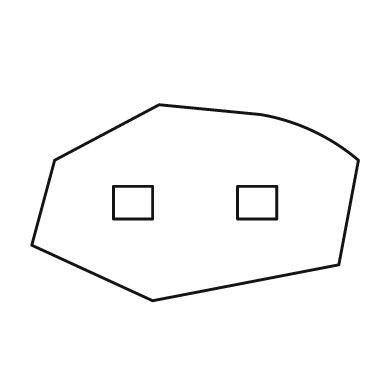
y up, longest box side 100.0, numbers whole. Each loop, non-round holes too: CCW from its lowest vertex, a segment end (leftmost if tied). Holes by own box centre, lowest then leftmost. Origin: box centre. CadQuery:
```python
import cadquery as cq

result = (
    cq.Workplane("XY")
    .moveTo(-13.0, -30.0)
    .lineTo(44.0, -19.0)
    .lineTo(50.0, 13.0)
    .threePointArc((36.0, 22.0), (20.0, 27.0))
    .lineTo(-11.0, 30.0)
    .lineTo(-43.0, 13.0)
    .lineTo(-50.0, -13.0)
    .close()
    .moveTo(-25.0, -5.0)
    .lineTo(-13.0, -5.0)
    .lineTo(-13.0, 5.0)
    .lineTo(-25.0, 5.0)
    .close()
    .moveTo(13.0, -5.0)
    .lineTo(25.0, -5.0)
    .lineTo(25.0, 5.0)
    .lineTo(13.0, 5.0)
    .close()
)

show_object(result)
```